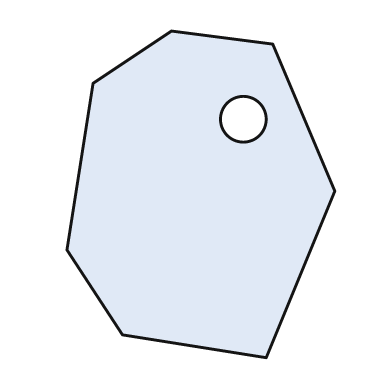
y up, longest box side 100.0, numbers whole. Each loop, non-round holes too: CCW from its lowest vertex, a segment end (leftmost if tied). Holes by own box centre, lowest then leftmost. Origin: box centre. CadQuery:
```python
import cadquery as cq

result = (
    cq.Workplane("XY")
    .moveTo(20.0, -50.0)
    .lineTo(41.0, 1.0)
    .lineTo(22.0, 46.0)
    .lineTo(-9.0, 50.0)
    .lineTo(-33.0, 34.0)
    .lineTo(-41.0, -17.0)
    .lineTo(-24.0, -43.0)
    .close()
    .moveTo(13.0, 23.0)
    .circle(7.0)
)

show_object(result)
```